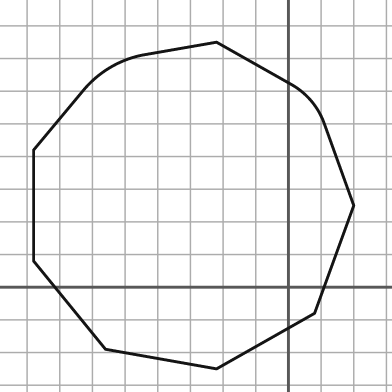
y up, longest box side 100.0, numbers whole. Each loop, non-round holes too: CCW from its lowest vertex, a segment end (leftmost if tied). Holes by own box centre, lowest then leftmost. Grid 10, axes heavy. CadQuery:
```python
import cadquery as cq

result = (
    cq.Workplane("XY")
    .moveTo(-22.0, -25.0)
    .lineTo(8.0, -8.0)
    .lineTo(20.0, 25.0)
    .lineTo(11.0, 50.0)
    .threePointArc((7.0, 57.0), (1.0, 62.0))
    .lineTo(-22.0, 75.0)
    .lineTo(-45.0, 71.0)
    .threePointArc((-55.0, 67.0), (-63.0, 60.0))
    .lineTo(-78.0, 42.0)
    .lineTo(-78.0, 8.0)
    .lineTo(-56.0, -19.0)
    .close()
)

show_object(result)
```